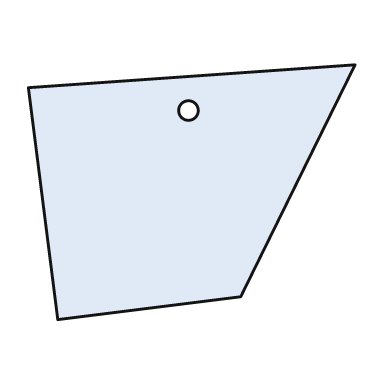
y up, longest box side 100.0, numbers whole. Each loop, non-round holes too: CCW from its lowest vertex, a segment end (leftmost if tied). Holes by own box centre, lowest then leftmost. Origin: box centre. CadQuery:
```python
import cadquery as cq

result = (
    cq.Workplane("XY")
    .moveTo(-41.0, -39.0)
    .lineTo(15.0, -32.0)
    .lineTo(50.0, 39.0)
    .lineTo(-50.0, 32.0)
    .close()
    .moveTo(-1.0, 25.0)
    .circle(3.0)
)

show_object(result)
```